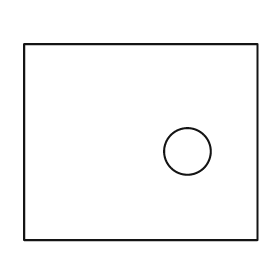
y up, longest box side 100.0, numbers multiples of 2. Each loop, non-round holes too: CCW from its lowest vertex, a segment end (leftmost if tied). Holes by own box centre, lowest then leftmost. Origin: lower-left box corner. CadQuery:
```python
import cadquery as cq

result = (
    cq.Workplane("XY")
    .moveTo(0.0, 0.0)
    .lineTo(100.0, 0.0)
    .lineTo(100.0, 84.0)
    .lineTo(0.0, 84.0)
    .close()
    .moveTo(70.0, 38.0)
    .circle(10.0)
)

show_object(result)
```